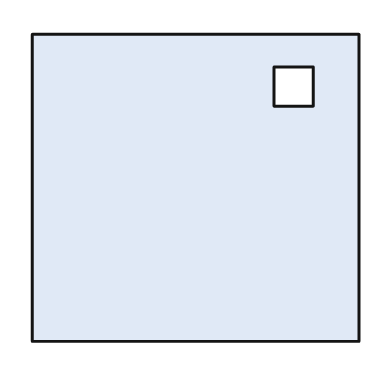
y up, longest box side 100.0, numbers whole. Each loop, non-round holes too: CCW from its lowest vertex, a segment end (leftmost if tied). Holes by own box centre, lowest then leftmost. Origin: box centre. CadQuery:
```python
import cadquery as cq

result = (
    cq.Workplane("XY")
    .moveTo(-50.0, -47.0)
    .lineTo(50.0, -47.0)
    .lineTo(50.0, 47.0)
    .lineTo(-50.0, 47.0)
    .close()
    .moveTo(24.0, 25.0)
    .lineTo(36.0, 25.0)
    .lineTo(36.0, 37.0)
    .lineTo(24.0, 37.0)
    .close()
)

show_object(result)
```